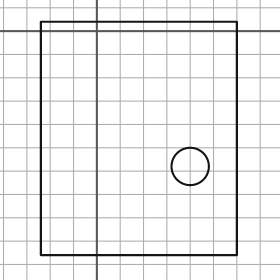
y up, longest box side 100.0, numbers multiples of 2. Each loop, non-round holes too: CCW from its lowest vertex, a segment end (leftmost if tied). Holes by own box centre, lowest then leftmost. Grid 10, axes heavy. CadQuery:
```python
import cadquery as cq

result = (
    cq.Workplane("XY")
    .moveTo(-24.0, -96.0)
    .lineTo(60.0, -96.0)
    .lineTo(60.0, 4.0)
    .lineTo(-24.0, 4.0)
    .close()
    .moveTo(40.0, -58.0)
    .circle(8.0)
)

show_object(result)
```